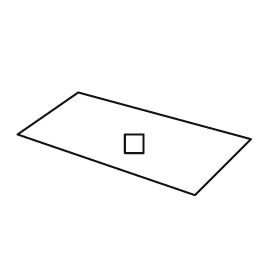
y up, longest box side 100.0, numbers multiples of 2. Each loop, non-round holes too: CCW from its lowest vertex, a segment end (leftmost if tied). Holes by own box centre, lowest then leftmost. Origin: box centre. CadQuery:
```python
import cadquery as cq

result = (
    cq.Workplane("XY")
    .moveTo(26.0, -22.0)
    .lineTo(50.0, 2.0)
    .lineTo(-24.0, 22.0)
    .lineTo(-50.0, 4.0)
    .close()
    .moveTo(-4.0, -4.0)
    .lineTo(4.0, -4.0)
    .lineTo(4.0, 4.0)
    .lineTo(-4.0, 4.0)
    .close()
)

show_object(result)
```